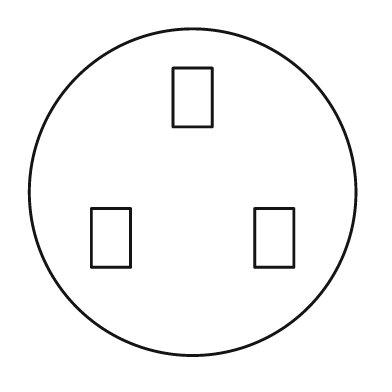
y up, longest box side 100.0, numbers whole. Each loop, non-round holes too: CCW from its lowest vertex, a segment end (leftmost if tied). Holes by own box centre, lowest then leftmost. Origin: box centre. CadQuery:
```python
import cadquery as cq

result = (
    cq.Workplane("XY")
    .moveTo(0.0, 0.0)
    .circle(50.0)
    .moveTo(-31.0, -23.0)
    .lineTo(-19.0, -23.0)
    .lineTo(-19.0, -5.0)
    .lineTo(-31.0, -5.0)
    .close()
    .moveTo(19.0, -23.0)
    .lineTo(31.0, -23.0)
    .lineTo(31.0, -5.0)
    .lineTo(19.0, -5.0)
    .close()
    .moveTo(-6.0, 20.0)
    .lineTo(6.0, 20.0)
    .lineTo(6.0, 38.0)
    .lineTo(-6.0, 38.0)
    .close()
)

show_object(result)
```